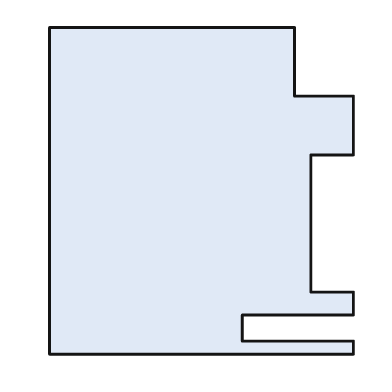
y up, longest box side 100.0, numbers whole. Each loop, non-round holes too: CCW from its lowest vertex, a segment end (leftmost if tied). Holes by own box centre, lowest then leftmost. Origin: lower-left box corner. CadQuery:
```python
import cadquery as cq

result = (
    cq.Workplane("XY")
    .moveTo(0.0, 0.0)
    .lineTo(93.0, 0.0)
    .lineTo(93.0, 4.0)
    .lineTo(59.0, 4.0)
    .lineTo(59.0, 12.0)
    .lineTo(93.0, 12.0)
    .lineTo(93.0, 19.0)
    .lineTo(80.0, 19.0)
    .lineTo(80.0, 61.0)
    .lineTo(93.0, 61.0)
    .lineTo(93.0, 79.0)
    .lineTo(75.0, 79.0)
    .lineTo(75.0, 100.0)
    .lineTo(0.0, 100.0)
    .close()
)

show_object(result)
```